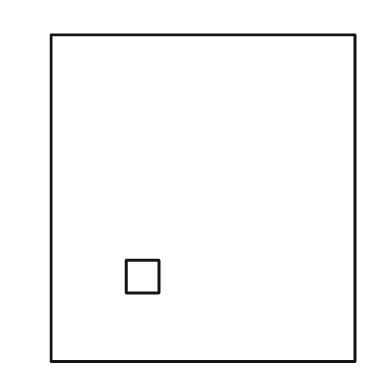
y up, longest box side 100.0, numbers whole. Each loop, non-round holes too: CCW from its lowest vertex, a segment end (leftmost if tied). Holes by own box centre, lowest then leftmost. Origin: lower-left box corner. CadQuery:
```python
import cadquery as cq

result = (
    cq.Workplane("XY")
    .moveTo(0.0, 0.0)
    .lineTo(93.0, 0.0)
    .lineTo(93.0, 100.0)
    .lineTo(0.0, 100.0)
    .close()
    .moveTo(23.0, 21.0)
    .lineTo(33.0, 21.0)
    .lineTo(33.0, 31.0)
    .lineTo(23.0, 31.0)
    .close()
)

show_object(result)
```